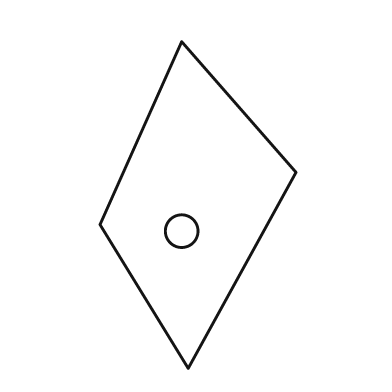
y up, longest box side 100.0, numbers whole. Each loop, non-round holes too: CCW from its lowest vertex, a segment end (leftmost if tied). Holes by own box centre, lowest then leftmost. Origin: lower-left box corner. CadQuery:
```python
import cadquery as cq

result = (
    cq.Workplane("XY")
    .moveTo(27.0, 0.0)
    .lineTo(60.0, 60.0)
    .lineTo(25.0, 100.0)
    .lineTo(0.0, 44.0)
    .close()
    .moveTo(25.0, 42.0)
    .circle(5.0)
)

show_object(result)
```